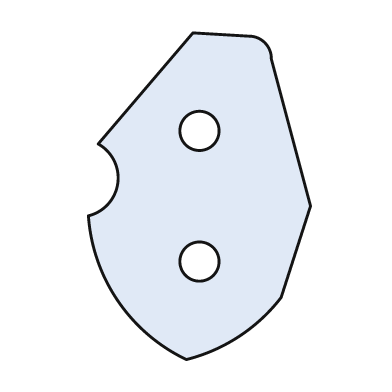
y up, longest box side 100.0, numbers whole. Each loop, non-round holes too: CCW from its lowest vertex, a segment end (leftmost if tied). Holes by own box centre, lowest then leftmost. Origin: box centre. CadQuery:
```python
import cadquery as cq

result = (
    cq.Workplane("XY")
    .moveTo(-4.0, -50.0)
    .threePointArc((12.0, -43.0), (25.0, -31.0))
    .lineTo(34.0, -3.0)
    .lineTo(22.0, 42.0)
    .threePointArc((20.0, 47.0), (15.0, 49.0))
    .lineTo(-2.0, 50.0)
    .lineTo(-31.0, 16.0)
    .threePointArc((-25.0, 4.0), (-34.0, -6.0))
    .threePointArc((-25.0, -32.0), (-4.0, -50.0))
    .close()
    .moveTo(0.0, -20.0)
    .circle(6.0)
    .moveTo(0.0, 20.0)
    .circle(6.0)
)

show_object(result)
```